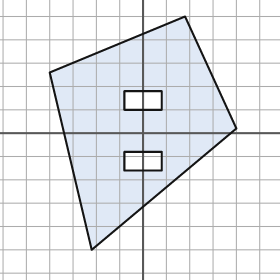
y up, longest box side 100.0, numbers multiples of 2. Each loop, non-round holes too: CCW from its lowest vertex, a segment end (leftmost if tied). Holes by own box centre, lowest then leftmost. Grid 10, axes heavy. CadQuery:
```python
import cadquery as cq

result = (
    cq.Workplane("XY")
    .moveTo(-22.0, -50.0)
    .lineTo(40.0, 2.0)
    .lineTo(18.0, 50.0)
    .lineTo(-40.0, 26.0)
    .close()
    .moveTo(-8.0, -16.0)
    .lineTo(8.0, -16.0)
    .lineTo(8.0, -8.0)
    .lineTo(-8.0, -8.0)
    .close()
    .moveTo(-8.0, 10.0)
    .lineTo(8.0, 10.0)
    .lineTo(8.0, 18.0)
    .lineTo(-8.0, 18.0)
    .close()
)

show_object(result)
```